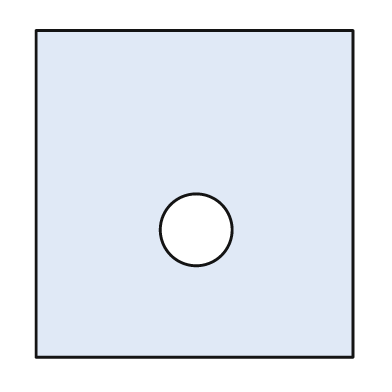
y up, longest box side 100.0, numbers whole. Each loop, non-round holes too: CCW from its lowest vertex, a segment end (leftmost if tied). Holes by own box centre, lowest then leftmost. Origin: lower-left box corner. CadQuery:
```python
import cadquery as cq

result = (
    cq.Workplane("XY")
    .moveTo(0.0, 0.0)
    .lineTo(97.0, 0.0)
    .lineTo(97.0, 100.0)
    .lineTo(0.0, 100.0)
    .close()
    .moveTo(49.0, 39.0)
    .circle(11.0)
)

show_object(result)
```